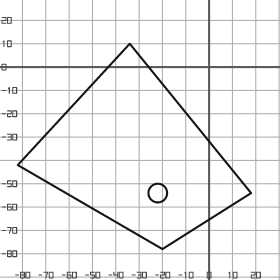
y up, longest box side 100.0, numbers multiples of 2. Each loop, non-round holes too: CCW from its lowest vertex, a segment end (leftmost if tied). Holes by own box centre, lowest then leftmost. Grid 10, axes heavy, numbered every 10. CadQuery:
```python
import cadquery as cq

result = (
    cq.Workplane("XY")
    .moveTo(-20.0, -78.0)
    .lineTo(18.0, -54.0)
    .lineTo(-34.0, 10.0)
    .lineTo(-82.0, -42.0)
    .close()
    .moveTo(-22.0, -54.0)
    .circle(4.0)
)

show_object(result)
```